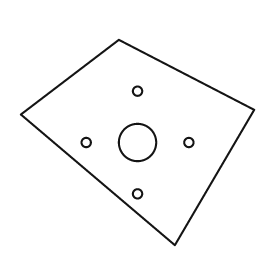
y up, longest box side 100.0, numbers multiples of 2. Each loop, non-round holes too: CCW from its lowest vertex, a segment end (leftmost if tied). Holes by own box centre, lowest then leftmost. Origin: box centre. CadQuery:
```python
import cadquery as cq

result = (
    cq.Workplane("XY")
    .moveTo(16.0, -44.0)
    .lineTo(50.0, 14.0)
    .lineTo(-8.0, 44.0)
    .lineTo(-50.0, 12.0)
    .close()
    .moveTo(0.0, -22.0)
    .circle(2.0)
    .moveTo(-22.0, 0.0)
    .circle(2.0)
    .moveTo(0.0, 0.0)
    .circle(8.0)
    .moveTo(22.0, 0.0)
    .circle(2.0)
    .moveTo(0.0, 22.0)
    .circle(2.0)
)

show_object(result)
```